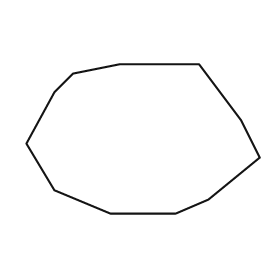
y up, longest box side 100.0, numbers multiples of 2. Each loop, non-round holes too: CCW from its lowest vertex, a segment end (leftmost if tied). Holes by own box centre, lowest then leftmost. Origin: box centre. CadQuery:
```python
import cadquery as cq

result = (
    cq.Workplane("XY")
    .moveTo(-14.0, -32.0)
    .lineTo(14.0, -32.0)
    .lineTo(28.0, -26.0)
    .lineTo(50.0, -8.0)
    .lineTo(42.0, 8.0)
    .lineTo(24.0, 32.0)
    .lineTo(-10.0, 32.0)
    .lineTo(-30.0, 28.0)
    .lineTo(-38.0, 20.0)
    .lineTo(-50.0, -2.0)
    .lineTo(-38.0, -22.0)
    .close()
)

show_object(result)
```